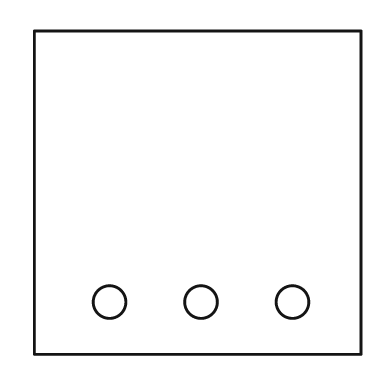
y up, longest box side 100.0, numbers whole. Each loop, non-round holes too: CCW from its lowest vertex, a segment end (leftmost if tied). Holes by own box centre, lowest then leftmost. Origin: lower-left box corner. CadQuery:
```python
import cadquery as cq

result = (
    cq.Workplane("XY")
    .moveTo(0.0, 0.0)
    .lineTo(100.0, 0.0)
    .lineTo(100.0, 99.0)
    .lineTo(0.0, 99.0)
    .close()
    .moveTo(23.0, 16.0)
    .circle(5.0)
    .moveTo(51.0, 16.0)
    .circle(5.0)
    .moveTo(79.0, 16.0)
    .circle(5.0)
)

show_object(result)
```